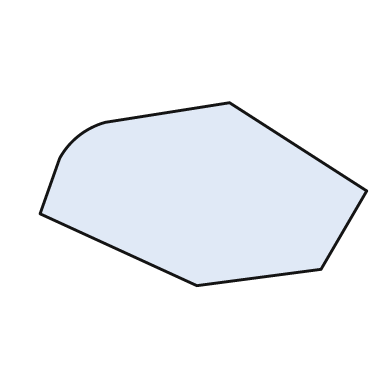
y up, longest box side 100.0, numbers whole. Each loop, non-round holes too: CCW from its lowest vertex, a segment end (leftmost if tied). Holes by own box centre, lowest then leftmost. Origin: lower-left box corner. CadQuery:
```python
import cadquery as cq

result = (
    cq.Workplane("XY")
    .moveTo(48.0, 0.0)
    .lineTo(86.0, 5.0)
    .lineTo(100.0, 29.0)
    .lineTo(58.0, 56.0)
    .lineTo(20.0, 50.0)
    .threePointArc((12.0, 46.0), (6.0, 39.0))
    .lineTo(0.0, 22.0)
    .close()
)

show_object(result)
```